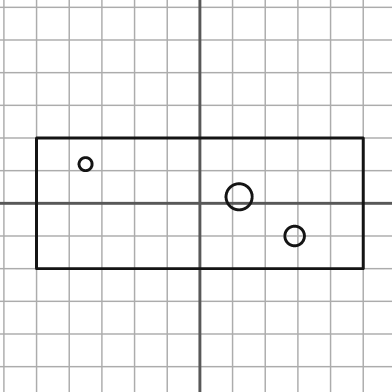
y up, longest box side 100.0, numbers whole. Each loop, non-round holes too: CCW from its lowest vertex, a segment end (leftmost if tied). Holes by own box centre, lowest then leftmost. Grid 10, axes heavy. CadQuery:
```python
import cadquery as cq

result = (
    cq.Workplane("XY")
    .moveTo(-50.0, -20.0)
    .lineTo(50.0, -20.0)
    .lineTo(50.0, 20.0)
    .lineTo(-50.0, 20.0)
    .close()
    .moveTo(29.0, -10.0)
    .circle(3.0)
    .moveTo(12.0, 2.0)
    .circle(4.0)
    .moveTo(-35.0, 12.0)
    .circle(2.0)
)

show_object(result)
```